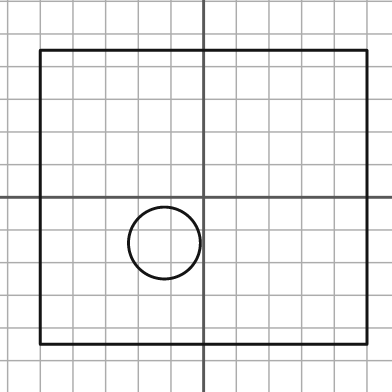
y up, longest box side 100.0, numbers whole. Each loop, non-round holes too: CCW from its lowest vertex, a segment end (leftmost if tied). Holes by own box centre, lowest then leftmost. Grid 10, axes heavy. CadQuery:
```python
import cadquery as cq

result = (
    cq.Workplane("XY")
    .moveTo(-50.0, -45.0)
    .lineTo(50.0, -45.0)
    .lineTo(50.0, 45.0)
    .lineTo(-50.0, 45.0)
    .close()
    .moveTo(-12.0, -14.0)
    .circle(11.0)
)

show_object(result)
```